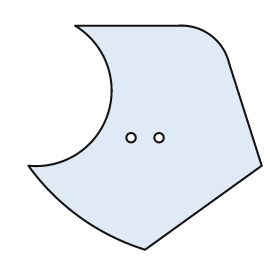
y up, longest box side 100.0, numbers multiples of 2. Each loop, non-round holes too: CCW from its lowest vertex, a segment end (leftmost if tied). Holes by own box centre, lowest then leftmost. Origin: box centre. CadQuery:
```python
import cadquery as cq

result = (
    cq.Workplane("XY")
    .moveTo(0.0, -48.0)
    .lineTo(50.0, -12.0)
    .lineTo(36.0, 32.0)
    .threePointArc((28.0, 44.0), (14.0, 48.0))
    .lineTo(-30.0, 48.0)
    .threePointArc((-16.0, 10.0), (-50.0, -12.0))
    .threePointArc((-28.0, -34.0), (0.0, -48.0))
    .close()
    .moveTo(-6.0, 0.0)
    .circle(2.0)
    .moveTo(6.0, 0.0)
    .circle(2.0)
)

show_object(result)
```